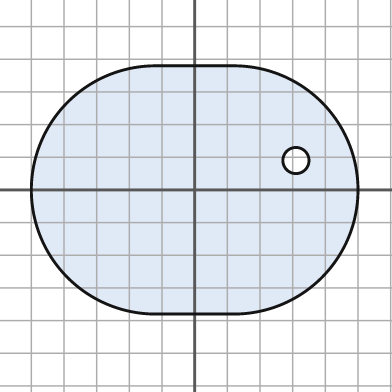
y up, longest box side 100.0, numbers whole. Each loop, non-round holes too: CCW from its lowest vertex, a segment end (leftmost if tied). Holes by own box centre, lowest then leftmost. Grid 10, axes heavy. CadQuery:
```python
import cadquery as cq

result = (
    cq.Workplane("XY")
    .moveTo(-12.0, -38.0)
    .lineTo(12.0, -38.0)
    .threePointArc((50.0, 0.0), (12.0, 38.0))
    .lineTo(-12.0, 38.0)
    .threePointArc((-50.0, 0.0), (-12.0, -38.0))
    .close()
    .moveTo(31.0, 9.0)
    .circle(4.0)
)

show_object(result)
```